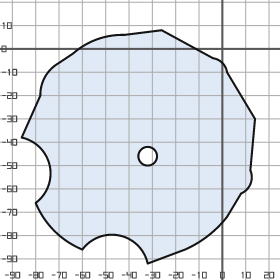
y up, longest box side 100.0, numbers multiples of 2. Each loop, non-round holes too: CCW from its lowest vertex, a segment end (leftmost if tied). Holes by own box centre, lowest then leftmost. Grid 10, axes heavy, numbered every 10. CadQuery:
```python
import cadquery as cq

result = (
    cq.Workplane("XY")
    .moveTo(-32.0, -92.0)
    .lineTo(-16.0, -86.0)
    .threePointArc((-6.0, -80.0), (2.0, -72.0))
    .lineTo(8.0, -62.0)
    .threePointArc((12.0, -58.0), (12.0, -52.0))
    .lineTo(14.0, -30.0)
    .lineTo(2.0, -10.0)
    .threePointArc((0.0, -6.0), (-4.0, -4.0))
    .lineTo(-26.0, 8.0)
    .lineTo(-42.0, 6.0)
    .threePointArc((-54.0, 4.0), (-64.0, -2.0))
    .lineTo(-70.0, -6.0)
    .threePointArc((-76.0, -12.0), (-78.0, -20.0))
    .lineTo(-86.0, -38.0)
    .threePointArc((-74.0, -50.0), (-80.0, -66.0))
    .threePointArc((-72.0, -78.0), (-60.0, -86.0))
    .threePointArc((-44.0, -80.0), (-32.0, -92.0))
    .close()
    .moveTo(-32.0, -46.0)
    .circle(4.0)
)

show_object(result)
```